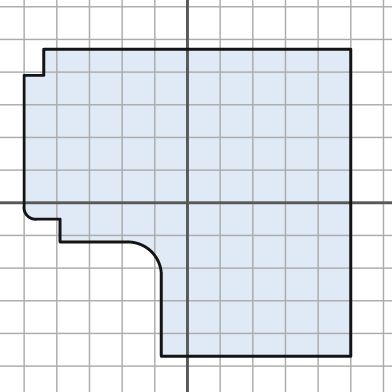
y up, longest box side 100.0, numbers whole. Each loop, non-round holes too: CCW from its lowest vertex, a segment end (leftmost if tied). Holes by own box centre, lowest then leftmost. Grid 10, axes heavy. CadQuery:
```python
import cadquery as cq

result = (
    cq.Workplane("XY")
    .moveTo(-8.0, -47.0)
    .lineTo(50.0, -47.0)
    .lineTo(50.0, 47.0)
    .lineTo(-44.0, 47.0)
    .lineTo(-44.0, 39.0)
    .lineTo(-50.0, 39.0)
    .lineTo(-50.0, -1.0)
    .threePointArc((-49.0, -4.0), (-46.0, -5.0))
    .lineTo(-39.0, -5.0)
    .lineTo(-39.0, -12.0)
    .lineTo(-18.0, -12.0)
    .threePointArc((-11.0, -15.0), (-8.0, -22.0))
    .close()
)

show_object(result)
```